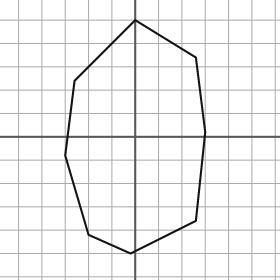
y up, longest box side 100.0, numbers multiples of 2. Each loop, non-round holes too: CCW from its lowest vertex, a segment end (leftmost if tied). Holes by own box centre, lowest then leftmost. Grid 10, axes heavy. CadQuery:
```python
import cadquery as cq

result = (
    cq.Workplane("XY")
    .moveTo(-2.0, -50.0)
    .lineTo(26.0, -36.0)
    .lineTo(30.0, 2.0)
    .lineTo(26.0, 34.0)
    .lineTo(0.0, 50.0)
    .lineTo(-26.0, 24.0)
    .lineTo(-30.0, -8.0)
    .lineTo(-20.0, -42.0)
    .close()
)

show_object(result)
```